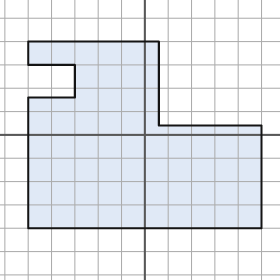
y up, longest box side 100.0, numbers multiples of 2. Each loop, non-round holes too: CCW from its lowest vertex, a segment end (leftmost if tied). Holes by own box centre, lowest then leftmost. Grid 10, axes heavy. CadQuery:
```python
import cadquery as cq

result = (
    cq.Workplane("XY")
    .moveTo(-50.0, -40.0)
    .lineTo(50.0, -40.0)
    .lineTo(50.0, 4.0)
    .lineTo(6.0, 4.0)
    .lineTo(6.0, 40.0)
    .lineTo(-50.0, 40.0)
    .lineTo(-50.0, 30.0)
    .lineTo(-30.0, 30.0)
    .lineTo(-30.0, 16.0)
    .lineTo(-50.0, 16.0)
    .close()
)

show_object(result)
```